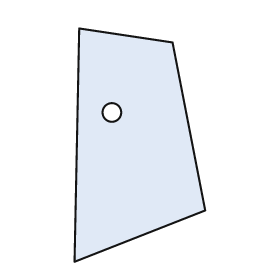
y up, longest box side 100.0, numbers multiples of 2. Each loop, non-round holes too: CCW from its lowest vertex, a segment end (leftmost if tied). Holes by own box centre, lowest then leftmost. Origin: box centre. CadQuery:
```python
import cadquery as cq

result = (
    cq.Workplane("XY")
    .moveTo(-28.0, -50.0)
    .lineTo(28.0, -28.0)
    .lineTo(14.0, 44.0)
    .lineTo(-26.0, 50.0)
    .close()
    .moveTo(-12.0, 14.0)
    .circle(4.0)
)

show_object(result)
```